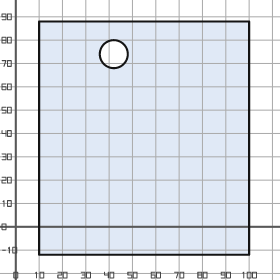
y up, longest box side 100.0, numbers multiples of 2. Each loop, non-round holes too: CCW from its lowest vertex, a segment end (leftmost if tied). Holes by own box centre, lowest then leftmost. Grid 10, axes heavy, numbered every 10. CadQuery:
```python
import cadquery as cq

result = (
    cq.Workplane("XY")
    .moveTo(10.0, -12.0)
    .lineTo(100.0, -12.0)
    .lineTo(100.0, 88.0)
    .lineTo(10.0, 88.0)
    .close()
    .moveTo(42.0, 74.0)
    .circle(6.0)
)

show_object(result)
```